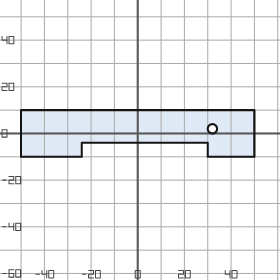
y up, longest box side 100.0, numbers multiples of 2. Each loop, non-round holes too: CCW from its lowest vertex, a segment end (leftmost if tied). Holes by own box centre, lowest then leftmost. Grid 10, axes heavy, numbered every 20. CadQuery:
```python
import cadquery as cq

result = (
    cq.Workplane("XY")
    .moveTo(-50.0, -10.0)
    .lineTo(-24.0, -10.0)
    .lineTo(-24.0, -4.0)
    .lineTo(30.0, -4.0)
    .lineTo(30.0, -10.0)
    .lineTo(50.0, -10.0)
    .lineTo(50.0, 10.0)
    .lineTo(-50.0, 10.0)
    .close()
    .moveTo(32.0, 2.0)
    .circle(2.0)
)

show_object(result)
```